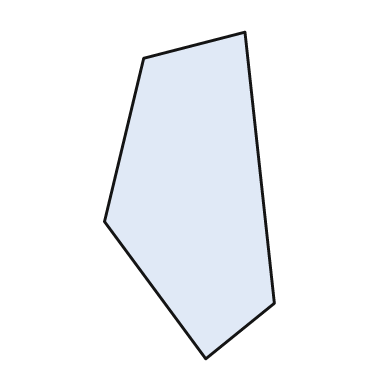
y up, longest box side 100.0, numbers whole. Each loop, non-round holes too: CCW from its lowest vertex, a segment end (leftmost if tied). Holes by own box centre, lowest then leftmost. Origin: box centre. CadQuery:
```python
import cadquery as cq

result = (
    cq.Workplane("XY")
    .moveTo(5.0, -50.0)
    .lineTo(26.0, -33.0)
    .lineTo(17.0, 50.0)
    .lineTo(-14.0, 42.0)
    .lineTo(-26.0, -8.0)
    .close()
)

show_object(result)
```